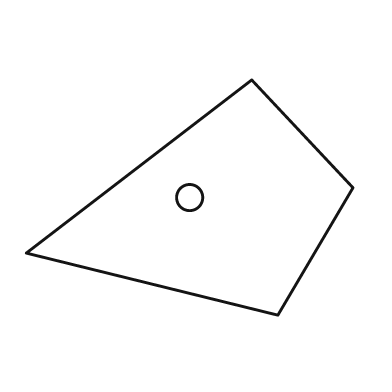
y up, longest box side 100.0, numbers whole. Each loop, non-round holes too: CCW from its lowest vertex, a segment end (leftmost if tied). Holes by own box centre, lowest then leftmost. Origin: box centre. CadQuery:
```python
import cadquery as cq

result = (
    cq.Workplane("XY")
    .moveTo(27.0, -36.0)
    .lineTo(50.0, 3.0)
    .lineTo(19.0, 36.0)
    .lineTo(-50.0, -17.0)
    .close()
    .moveTo(0.0, 0.0)
    .circle(4.0)
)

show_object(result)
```